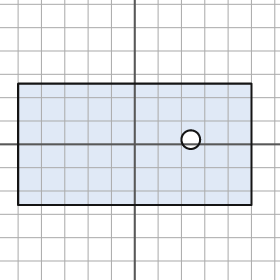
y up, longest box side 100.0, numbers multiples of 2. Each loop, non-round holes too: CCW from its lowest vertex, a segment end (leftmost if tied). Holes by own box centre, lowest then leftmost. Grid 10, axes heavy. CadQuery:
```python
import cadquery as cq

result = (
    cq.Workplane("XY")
    .moveTo(-50.0, -26.0)
    .lineTo(50.0, -26.0)
    .lineTo(50.0, 26.0)
    .lineTo(-50.0, 26.0)
    .close()
    .moveTo(24.0, 2.0)
    .circle(4.0)
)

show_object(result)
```